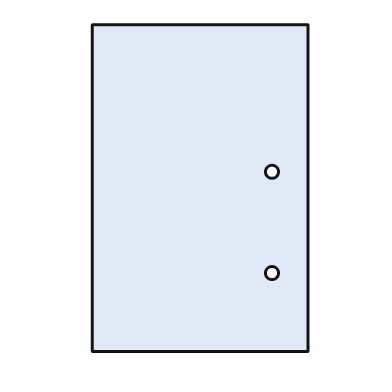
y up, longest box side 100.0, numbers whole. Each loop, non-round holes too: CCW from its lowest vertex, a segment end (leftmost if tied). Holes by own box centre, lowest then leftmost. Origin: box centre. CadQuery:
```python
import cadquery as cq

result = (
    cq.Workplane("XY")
    .moveTo(-33.0, -50.0)
    .lineTo(33.0, -50.0)
    .lineTo(33.0, 50.0)
    .lineTo(-33.0, 50.0)
    .close()
    .moveTo(22.0, -26.0)
    .circle(2.0)
    .moveTo(22.0, 5.0)
    .circle(2.0)
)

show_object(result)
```